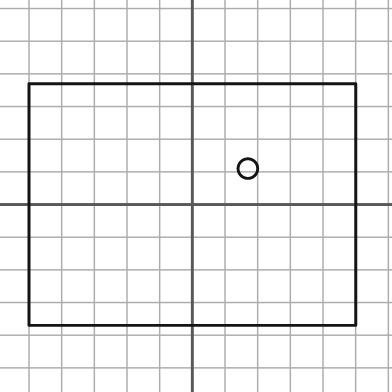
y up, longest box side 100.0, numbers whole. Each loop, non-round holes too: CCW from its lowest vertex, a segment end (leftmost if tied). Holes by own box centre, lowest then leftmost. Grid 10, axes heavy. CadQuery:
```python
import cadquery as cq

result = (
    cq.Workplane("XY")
    .moveTo(-50.0, -37.0)
    .lineTo(50.0, -37.0)
    .lineTo(50.0, 37.0)
    .lineTo(-50.0, 37.0)
    .close()
    .moveTo(17.0, 11.0)
    .circle(3.0)
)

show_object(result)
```